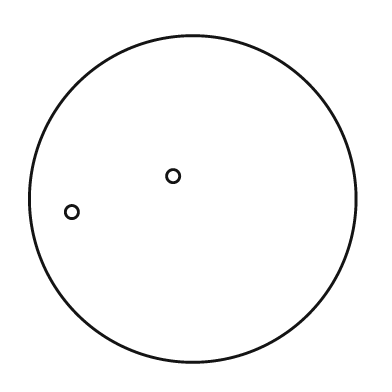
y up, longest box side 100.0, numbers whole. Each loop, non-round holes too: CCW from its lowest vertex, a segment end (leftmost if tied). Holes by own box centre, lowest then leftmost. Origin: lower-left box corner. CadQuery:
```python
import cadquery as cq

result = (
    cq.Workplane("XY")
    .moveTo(50.0, 50.0)
    .circle(50.0)
    .moveTo(13.0, 46.0)
    .circle(2.0)
    .moveTo(44.0, 57.0)
    .circle(2.0)
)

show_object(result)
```